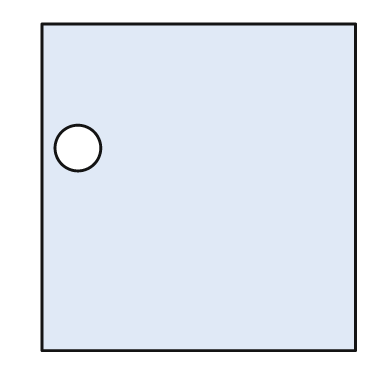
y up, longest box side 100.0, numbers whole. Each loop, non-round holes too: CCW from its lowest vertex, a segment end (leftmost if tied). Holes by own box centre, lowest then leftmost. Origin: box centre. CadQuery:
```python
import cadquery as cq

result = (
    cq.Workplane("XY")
    .moveTo(-48.0, -50.0)
    .lineTo(48.0, -50.0)
    .lineTo(48.0, 50.0)
    .lineTo(-48.0, 50.0)
    .close()
    .moveTo(-37.0, 12.0)
    .circle(7.0)
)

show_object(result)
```